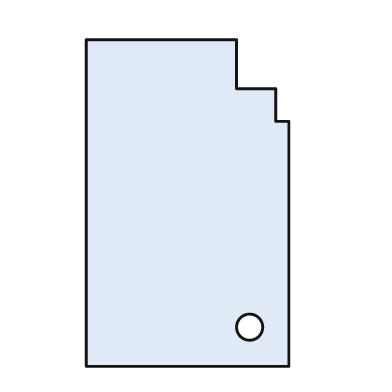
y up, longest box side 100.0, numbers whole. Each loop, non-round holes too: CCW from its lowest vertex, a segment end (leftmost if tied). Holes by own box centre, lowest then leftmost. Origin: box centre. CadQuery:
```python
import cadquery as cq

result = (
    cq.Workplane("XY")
    .moveTo(-31.0, -50.0)
    .lineTo(31.0, -50.0)
    .lineTo(31.0, 25.0)
    .lineTo(27.0, 25.0)
    .lineTo(27.0, 35.0)
    .lineTo(15.0, 35.0)
    .lineTo(15.0, 50.0)
    .lineTo(-31.0, 50.0)
    .close()
    .moveTo(19.0, -38.0)
    .circle(4.0)
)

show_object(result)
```